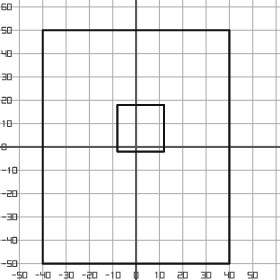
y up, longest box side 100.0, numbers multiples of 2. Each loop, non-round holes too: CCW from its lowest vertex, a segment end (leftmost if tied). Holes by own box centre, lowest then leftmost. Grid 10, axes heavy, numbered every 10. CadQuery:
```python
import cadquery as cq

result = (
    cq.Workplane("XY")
    .moveTo(-40.0, -50.0)
    .lineTo(40.0, -50.0)
    .lineTo(40.0, 50.0)
    .lineTo(-40.0, 50.0)
    .close()
    .moveTo(-8.0, -2.0)
    .lineTo(12.0, -2.0)
    .lineTo(12.0, 18.0)
    .lineTo(-8.0, 18.0)
    .close()
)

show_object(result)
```